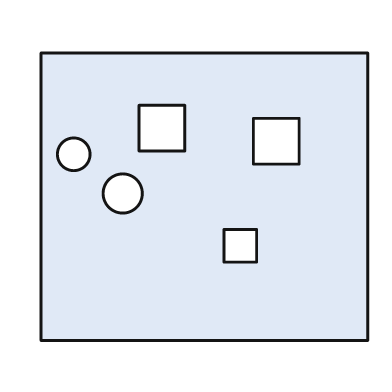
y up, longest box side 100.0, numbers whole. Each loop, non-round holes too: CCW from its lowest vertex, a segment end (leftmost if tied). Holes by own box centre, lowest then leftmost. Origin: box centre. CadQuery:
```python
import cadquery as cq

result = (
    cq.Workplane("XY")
    .moveTo(-50.0, -44.0)
    .lineTo(50.0, -44.0)
    .lineTo(50.0, 44.0)
    .lineTo(-50.0, 44.0)
    .close()
    .moveTo(6.0, -20.0)
    .lineTo(16.0, -20.0)
    .lineTo(16.0, -10.0)
    .lineTo(6.0, -10.0)
    .close()
    .moveTo(-25.0, 1.0)
    .circle(6.0)
    .moveTo(-40.0, 13.0)
    .circle(5.0)
    .moveTo(15.0, 10.0)
    .lineTo(29.0, 10.0)
    .lineTo(29.0, 24.0)
    .lineTo(15.0, 24.0)
    .close()
    .moveTo(-20.0, 14.0)
    .lineTo(-6.0, 14.0)
    .lineTo(-6.0, 28.0)
    .lineTo(-20.0, 28.0)
    .close()
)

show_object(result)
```